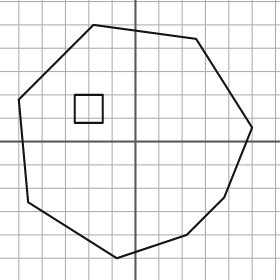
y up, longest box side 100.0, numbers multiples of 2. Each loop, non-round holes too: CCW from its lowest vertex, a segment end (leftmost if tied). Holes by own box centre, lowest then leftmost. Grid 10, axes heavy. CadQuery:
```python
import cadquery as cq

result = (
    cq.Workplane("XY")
    .moveTo(-8.0, -50.0)
    .lineTo(22.0, -40.0)
    .lineTo(38.0, -24.0)
    .lineTo(50.0, 6.0)
    .lineTo(26.0, 44.0)
    .lineTo(-18.0, 50.0)
    .lineTo(-50.0, 18.0)
    .lineTo(-46.0, -26.0)
    .close()
    .moveTo(-26.0, 8.0)
    .lineTo(-14.0, 8.0)
    .lineTo(-14.0, 20.0)
    .lineTo(-26.0, 20.0)
    .close()
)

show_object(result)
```